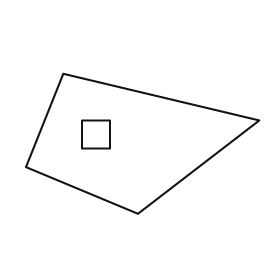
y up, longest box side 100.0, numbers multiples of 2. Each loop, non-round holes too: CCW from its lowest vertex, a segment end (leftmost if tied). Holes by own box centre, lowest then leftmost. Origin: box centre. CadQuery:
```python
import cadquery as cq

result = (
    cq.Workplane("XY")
    .moveTo(-2.0, -30.0)
    .lineTo(50.0, 10.0)
    .lineTo(-34.0, 30.0)
    .lineTo(-50.0, -10.0)
    .close()
    .moveTo(-26.0, -2.0)
    .lineTo(-14.0, -2.0)
    .lineTo(-14.0, 10.0)
    .lineTo(-26.0, 10.0)
    .close()
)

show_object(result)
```